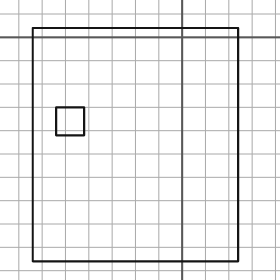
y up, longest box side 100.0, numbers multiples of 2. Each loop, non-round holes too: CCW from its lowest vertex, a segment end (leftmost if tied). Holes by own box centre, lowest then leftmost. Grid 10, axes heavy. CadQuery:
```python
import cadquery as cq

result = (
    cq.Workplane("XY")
    .moveTo(-64.0, -96.0)
    .lineTo(24.0, -96.0)
    .lineTo(24.0, 4.0)
    .lineTo(-64.0, 4.0)
    .close()
    .moveTo(-54.0, -42.0)
    .lineTo(-42.0, -42.0)
    .lineTo(-42.0, -30.0)
    .lineTo(-54.0, -30.0)
    .close()
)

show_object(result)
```